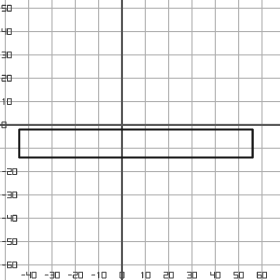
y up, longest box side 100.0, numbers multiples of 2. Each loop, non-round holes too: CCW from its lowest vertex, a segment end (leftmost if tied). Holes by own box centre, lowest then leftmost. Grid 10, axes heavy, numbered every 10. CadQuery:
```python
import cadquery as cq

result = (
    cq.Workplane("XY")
    .moveTo(-44.0, -14.0)
    .lineTo(56.0, -14.0)
    .lineTo(56.0, -2.0)
    .lineTo(-44.0, -2.0)
    .close()
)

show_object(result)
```